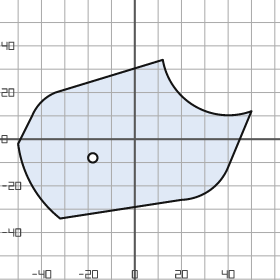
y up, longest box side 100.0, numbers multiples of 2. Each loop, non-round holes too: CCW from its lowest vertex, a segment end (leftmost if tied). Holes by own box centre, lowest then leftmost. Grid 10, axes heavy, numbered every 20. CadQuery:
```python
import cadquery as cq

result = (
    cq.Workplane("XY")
    .moveTo(-32.0, -34.0)
    .lineTo(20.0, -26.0)
    .threePointArc((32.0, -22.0), (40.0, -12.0))
    .lineTo(50.0, 12.0)
    .threePointArc((26.0, 14.0), (12.0, 34.0))
    .lineTo(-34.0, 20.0)
    .threePointArc((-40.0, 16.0), (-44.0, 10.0))
    .lineTo(-50.0, -2.0)
    .threePointArc((-44.0, -20.0), (-32.0, -34.0))
    .close()
    .moveTo(-18.0, -8.0)
    .circle(2.0)
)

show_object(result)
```